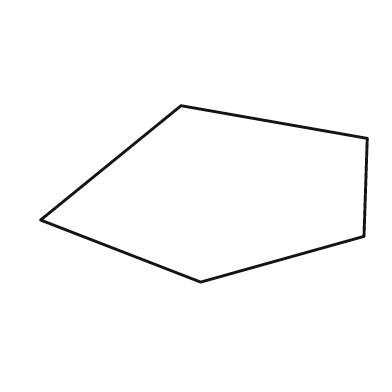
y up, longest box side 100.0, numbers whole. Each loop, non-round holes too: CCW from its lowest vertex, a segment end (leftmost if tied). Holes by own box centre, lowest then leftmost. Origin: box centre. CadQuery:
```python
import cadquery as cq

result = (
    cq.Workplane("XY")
    .moveTo(-1.0, -27.0)
    .lineTo(49.0, -13.0)
    .lineTo(50.0, 17.0)
    .lineTo(-7.0, 27.0)
    .lineTo(-50.0, -8.0)
    .close()
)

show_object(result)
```